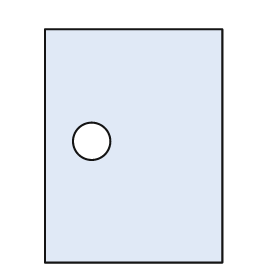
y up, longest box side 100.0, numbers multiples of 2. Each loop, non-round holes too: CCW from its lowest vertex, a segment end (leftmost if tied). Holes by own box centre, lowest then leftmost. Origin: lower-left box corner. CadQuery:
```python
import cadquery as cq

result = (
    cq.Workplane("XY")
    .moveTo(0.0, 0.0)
    .lineTo(76.0, 0.0)
    .lineTo(76.0, 100.0)
    .lineTo(0.0, 100.0)
    .close()
    .moveTo(20.0, 52.0)
    .circle(8.0)
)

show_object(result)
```